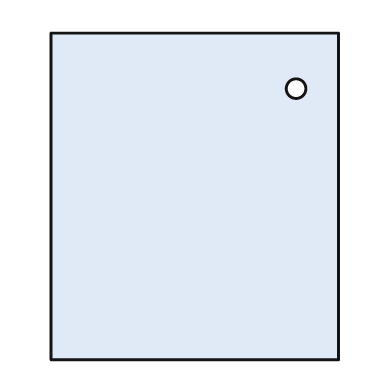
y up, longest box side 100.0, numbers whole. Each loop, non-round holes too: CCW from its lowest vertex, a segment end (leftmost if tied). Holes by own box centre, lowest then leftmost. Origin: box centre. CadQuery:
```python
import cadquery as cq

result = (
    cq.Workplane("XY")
    .moveTo(-44.0, -50.0)
    .lineTo(44.0, -50.0)
    .lineTo(44.0, 50.0)
    .lineTo(-44.0, 50.0)
    .close()
    .moveTo(31.0, 33.0)
    .circle(3.0)
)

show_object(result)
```